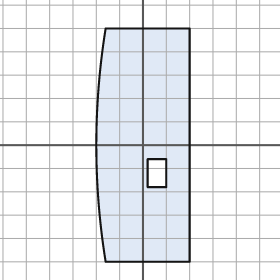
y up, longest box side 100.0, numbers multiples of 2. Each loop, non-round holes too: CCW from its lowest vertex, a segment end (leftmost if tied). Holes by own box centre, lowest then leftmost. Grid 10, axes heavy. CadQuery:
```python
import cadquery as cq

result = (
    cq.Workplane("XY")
    .moveTo(-16.0, -50.0)
    .lineTo(20.0, -50.0)
    .lineTo(20.0, 50.0)
    .lineTo(-16.0, 50.0)
    .threePointArc((-20.0, 0.0), (-16.0, -50.0))
    .close()
    .moveTo(2.0, -18.0)
    .lineTo(10.0, -18.0)
    .lineTo(10.0, -6.0)
    .lineTo(2.0, -6.0)
    .close()
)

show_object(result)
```